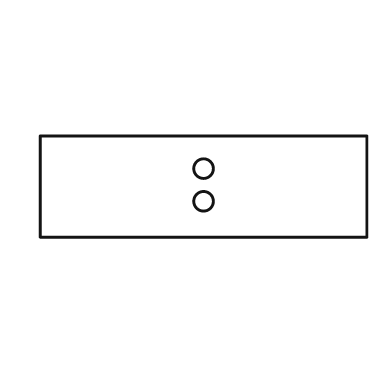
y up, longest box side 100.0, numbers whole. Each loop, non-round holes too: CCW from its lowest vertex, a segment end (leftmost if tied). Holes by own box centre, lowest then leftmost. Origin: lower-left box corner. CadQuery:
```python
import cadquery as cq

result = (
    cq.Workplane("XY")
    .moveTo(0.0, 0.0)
    .lineTo(100.0, 0.0)
    .lineTo(100.0, 31.0)
    .lineTo(0.0, 31.0)
    .close()
    .moveTo(50.0, 11.0)
    .circle(3.0)
    .moveTo(50.0, 21.0)
    .circle(3.0)
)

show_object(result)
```